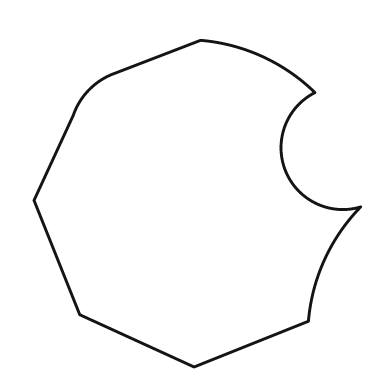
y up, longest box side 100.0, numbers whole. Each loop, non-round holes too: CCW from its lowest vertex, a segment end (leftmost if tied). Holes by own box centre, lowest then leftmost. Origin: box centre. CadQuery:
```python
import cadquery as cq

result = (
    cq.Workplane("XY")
    .moveTo(-1.0, -50.0)
    .lineTo(34.0, -36.0)
    .threePointArc((39.0, -17.0), (50.0, -1.0))
    .threePointArc((27.0, 10.0), (36.0, 34.0))
    .threePointArc((20.0, 45.0), (1.0, 50.0))
    .lineTo(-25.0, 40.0)
    .threePointArc((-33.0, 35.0), (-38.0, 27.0))
    .lineTo(-50.0, 1.0)
    .lineTo(-36.0, -34.0)
    .close()
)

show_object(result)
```